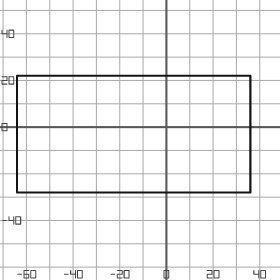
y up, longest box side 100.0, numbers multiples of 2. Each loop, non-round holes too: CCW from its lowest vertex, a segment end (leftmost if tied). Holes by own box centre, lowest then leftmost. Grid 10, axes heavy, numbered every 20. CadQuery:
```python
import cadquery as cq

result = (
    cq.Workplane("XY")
    .moveTo(-64.0, -28.0)
    .lineTo(36.0, -28.0)
    .lineTo(36.0, 22.0)
    .lineTo(-64.0, 22.0)
    .close()
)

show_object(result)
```